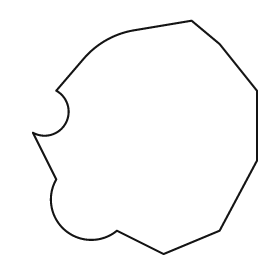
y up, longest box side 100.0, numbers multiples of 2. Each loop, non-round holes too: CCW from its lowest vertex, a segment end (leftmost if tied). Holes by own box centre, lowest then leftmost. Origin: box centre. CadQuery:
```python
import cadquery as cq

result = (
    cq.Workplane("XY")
    .moveTo(8.0, -50.0)
    .lineTo(32.0, -40.0)
    .lineTo(48.0, -10.0)
    .lineTo(48.0, 20.0)
    .lineTo(32.0, 40.0)
    .lineTo(20.0, 50.0)
    .lineTo(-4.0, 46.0)
    .threePointArc((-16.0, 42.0), (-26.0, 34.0))
    .lineTo(-38.0, 20.0)
    .threePointArc((-34.0, 6.0), (-48.0, 2.0))
    .lineTo(-38.0, -18.0)
    .threePointArc((-34.0, -40.0), (-12.0, -40.0))
    .close()
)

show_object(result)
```